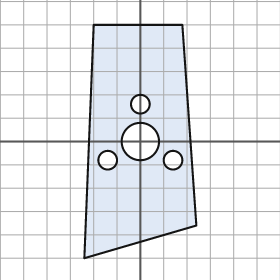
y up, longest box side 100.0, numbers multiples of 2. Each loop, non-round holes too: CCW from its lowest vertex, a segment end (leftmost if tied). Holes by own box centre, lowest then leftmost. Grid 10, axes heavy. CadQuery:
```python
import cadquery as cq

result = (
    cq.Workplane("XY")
    .moveTo(-24.0, -50.0)
    .lineTo(24.0, -36.0)
    .lineTo(18.0, 50.0)
    .lineTo(-20.0, 50.0)
    .close()
    .moveTo(-14.0, -8.0)
    .circle(4.0)
    .moveTo(14.0, -8.0)
    .circle(4.0)
    .moveTo(0.0, 0.0)
    .circle(8.0)
    .moveTo(0.0, 16.0)
    .circle(4.0)
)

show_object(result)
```